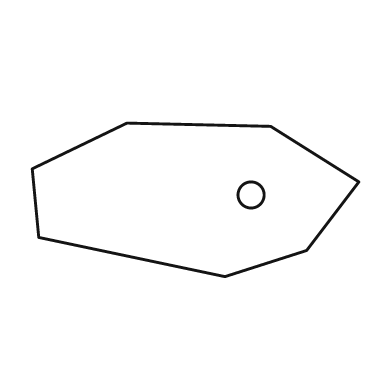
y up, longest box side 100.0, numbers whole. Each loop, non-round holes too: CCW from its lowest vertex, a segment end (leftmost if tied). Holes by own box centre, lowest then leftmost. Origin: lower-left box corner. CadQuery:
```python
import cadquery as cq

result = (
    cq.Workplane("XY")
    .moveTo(59.0, 0.0)
    .lineTo(84.0, 8.0)
    .lineTo(100.0, 29.0)
    .lineTo(73.0, 46.0)
    .lineTo(29.0, 47.0)
    .lineTo(0.0, 33.0)
    .lineTo(2.0, 12.0)
    .close()
    .moveTo(67.0, 25.0)
    .circle(4.0)
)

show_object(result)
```